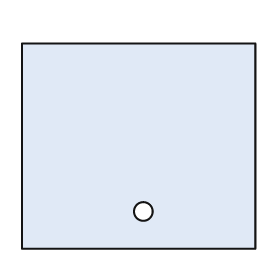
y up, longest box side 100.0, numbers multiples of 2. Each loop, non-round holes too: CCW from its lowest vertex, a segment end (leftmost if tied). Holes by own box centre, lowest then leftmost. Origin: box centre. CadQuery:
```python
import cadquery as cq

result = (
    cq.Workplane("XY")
    .moveTo(-50.0, -44.0)
    .lineTo(50.0, -44.0)
    .lineTo(50.0, 44.0)
    .lineTo(-50.0, 44.0)
    .close()
    .moveTo(2.0, -28.0)
    .circle(4.0)
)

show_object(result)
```